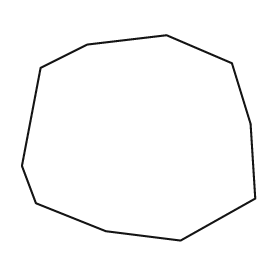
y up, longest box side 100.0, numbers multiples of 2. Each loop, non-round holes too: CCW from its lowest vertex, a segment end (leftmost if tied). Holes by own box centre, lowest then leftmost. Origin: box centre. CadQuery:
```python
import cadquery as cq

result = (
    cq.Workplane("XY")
    .moveTo(18.0, -44.0)
    .lineTo(50.0, -26.0)
    .lineTo(48.0, 6.0)
    .lineTo(40.0, 32.0)
    .lineTo(12.0, 44.0)
    .lineTo(-22.0, 40.0)
    .lineTo(-42.0, 30.0)
    .lineTo(-50.0, -12.0)
    .lineTo(-44.0, -28.0)
    .lineTo(-14.0, -40.0)
    .close()
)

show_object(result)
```